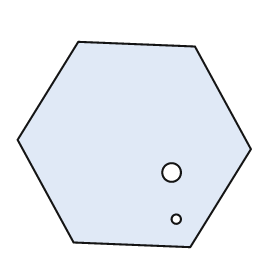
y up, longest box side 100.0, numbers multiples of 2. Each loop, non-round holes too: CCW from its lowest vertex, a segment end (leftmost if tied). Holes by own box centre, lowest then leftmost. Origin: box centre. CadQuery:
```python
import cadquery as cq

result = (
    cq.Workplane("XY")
    .moveTo(24.0, -44.0)
    .lineTo(50.0, -2.0)
    .lineTo(26.0, 42.0)
    .lineTo(-24.0, 44.0)
    .lineTo(-50.0, 2.0)
    .lineTo(-26.0, -42.0)
    .close()
    .moveTo(18.0, -32.0)
    .circle(2.0)
    .moveTo(16.0, -12.0)
    .circle(4.0)
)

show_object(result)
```